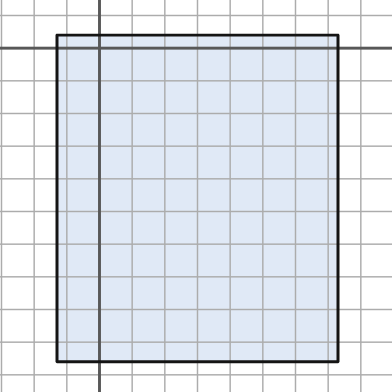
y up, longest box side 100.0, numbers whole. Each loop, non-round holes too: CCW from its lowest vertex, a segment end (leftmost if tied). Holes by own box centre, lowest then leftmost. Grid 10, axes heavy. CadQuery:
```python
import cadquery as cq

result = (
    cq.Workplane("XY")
    .moveTo(-13.0, -96.0)
    .lineTo(73.0, -96.0)
    .lineTo(73.0, 4.0)
    .lineTo(-13.0, 4.0)
    .close()
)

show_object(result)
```